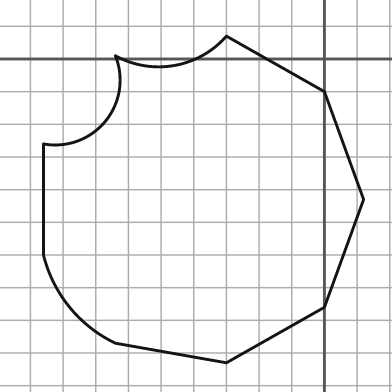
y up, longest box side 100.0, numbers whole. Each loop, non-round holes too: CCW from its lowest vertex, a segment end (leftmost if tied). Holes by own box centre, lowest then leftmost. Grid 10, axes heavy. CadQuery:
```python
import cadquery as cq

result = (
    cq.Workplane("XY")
    .moveTo(-30.0, -93.0)
    .lineTo(0.0, -76.0)
    .lineTo(12.0, -43.0)
    .lineTo(0.0, -10.0)
    .lineTo(-30.0, 7.0)
    .threePointArc((-46.0, -2.0), (-64.0, 1.0))
    .threePointArc((-67.0, -19.0), (-86.0, -26.0))
    .lineTo(-86.0, -60.0)
    .threePointArc((-78.0, -76.0), (-64.0, -87.0))
    .close()
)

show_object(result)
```